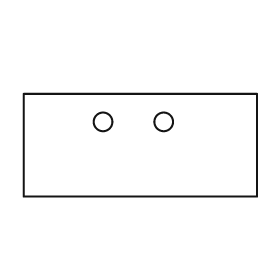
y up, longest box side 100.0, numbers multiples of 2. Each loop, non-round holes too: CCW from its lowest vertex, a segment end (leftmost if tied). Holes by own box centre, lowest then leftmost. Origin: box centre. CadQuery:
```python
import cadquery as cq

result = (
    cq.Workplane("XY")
    .moveTo(-50.0, -22.0)
    .lineTo(50.0, -22.0)
    .lineTo(50.0, 22.0)
    .lineTo(-50.0, 22.0)
    .close()
    .moveTo(-16.0, 10.0)
    .circle(4.0)
    .moveTo(10.0, 10.0)
    .circle(4.0)
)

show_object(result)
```